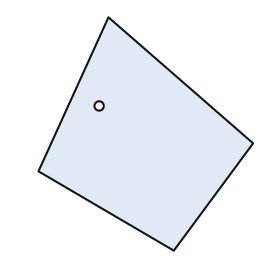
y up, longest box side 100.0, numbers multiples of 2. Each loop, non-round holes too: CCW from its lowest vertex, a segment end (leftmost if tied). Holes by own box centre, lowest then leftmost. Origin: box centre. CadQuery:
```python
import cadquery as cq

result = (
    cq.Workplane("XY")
    .moveTo(12.0, -50.0)
    .lineTo(46.0, -4.0)
    .lineTo(-16.0, 50.0)
    .lineTo(-46.0, -16.0)
    .close()
    .moveTo(-20.0, 12.0)
    .circle(2.0)
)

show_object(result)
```